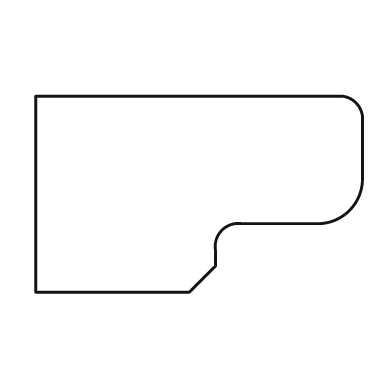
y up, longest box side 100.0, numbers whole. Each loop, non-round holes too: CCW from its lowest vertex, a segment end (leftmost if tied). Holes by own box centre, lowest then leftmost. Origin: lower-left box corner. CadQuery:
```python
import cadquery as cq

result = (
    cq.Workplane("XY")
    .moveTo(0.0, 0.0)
    .lineTo(47.0, 0.0)
    .lineTo(55.0, 8.0)
    .lineTo(55.0, 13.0)
    .threePointArc((57.0, 19.0), (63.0, 21.0))
    .lineTo(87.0, 21.0)
    .threePointArc((96.0, 25.0), (100.0, 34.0))
    .lineTo(100.0, 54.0)
    .threePointArc((98.0, 58.0), (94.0, 60.0))
    .lineTo(0.0, 60.0)
    .close()
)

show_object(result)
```